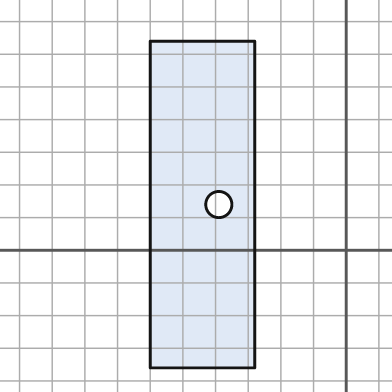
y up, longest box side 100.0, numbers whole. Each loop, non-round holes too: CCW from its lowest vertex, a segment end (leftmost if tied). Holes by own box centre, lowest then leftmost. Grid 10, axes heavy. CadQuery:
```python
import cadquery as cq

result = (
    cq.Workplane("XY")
    .moveTo(-60.0, -36.0)
    .lineTo(-28.0, -36.0)
    .lineTo(-28.0, 64.0)
    .lineTo(-60.0, 64.0)
    .close()
    .moveTo(-39.0, 14.0)
    .circle(4.0)
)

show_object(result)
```